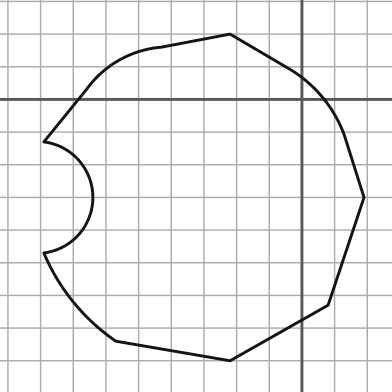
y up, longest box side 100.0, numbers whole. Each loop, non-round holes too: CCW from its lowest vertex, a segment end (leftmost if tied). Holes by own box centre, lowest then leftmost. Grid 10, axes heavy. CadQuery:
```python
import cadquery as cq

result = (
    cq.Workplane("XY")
    .moveTo(-22.0, -80.0)
    .lineTo(8.0, -63.0)
    .lineTo(19.0, -30.0)
    .lineTo(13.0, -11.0)
    .threePointArc((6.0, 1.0), (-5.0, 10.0))
    .lineTo(-22.0, 20.0)
    .lineTo(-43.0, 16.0)
    .threePointArc((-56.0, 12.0), (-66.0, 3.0))
    .lineTo(-79.0, -13.0)
    .threePointArc((-64.0, -30.0), (-79.0, -47.0))
    .threePointArc((-70.0, -62.0), (-57.0, -74.0))
    .close()
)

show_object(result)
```